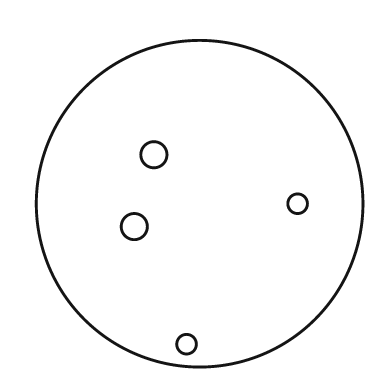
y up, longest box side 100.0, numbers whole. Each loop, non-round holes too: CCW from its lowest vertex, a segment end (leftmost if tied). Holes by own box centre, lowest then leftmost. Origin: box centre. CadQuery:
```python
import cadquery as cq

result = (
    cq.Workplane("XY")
    .moveTo(0.0, 0.0)
    .circle(50.0)
    .moveTo(-4.0, -43.0)
    .circle(3.0)
    .moveTo(-20.0, -7.0)
    .circle(4.0)
    .moveTo(30.0, 0.0)
    .circle(3.0)
    .moveTo(-14.0, 15.0)
    .circle(4.0)
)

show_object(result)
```